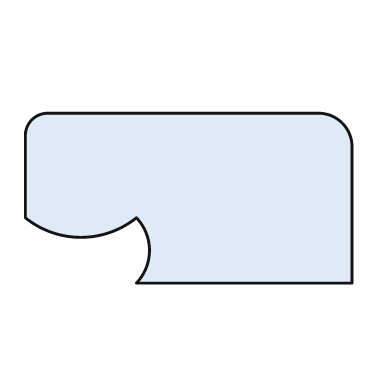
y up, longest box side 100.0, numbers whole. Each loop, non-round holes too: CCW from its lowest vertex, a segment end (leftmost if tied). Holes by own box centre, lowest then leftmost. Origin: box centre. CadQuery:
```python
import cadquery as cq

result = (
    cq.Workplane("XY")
    .moveTo(-16.0, -26.0)
    .lineTo(50.0, -26.0)
    .lineTo(50.0, 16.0)
    .threePointArc((47.0, 23.0), (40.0, 26.0))
    .lineTo(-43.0, 26.0)
    .threePointArc((-48.0, 24.0), (-50.0, 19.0))
    .lineTo(-50.0, -6.0)
    .threePointArc((-33.0, -12.0), (-16.0, -6.0))
    .threePointArc((-12.0, -16.0), (-16.0, -26.0))
    .close()
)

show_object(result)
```